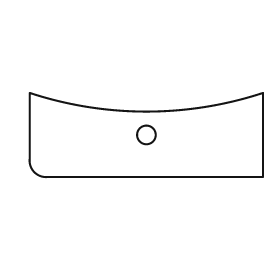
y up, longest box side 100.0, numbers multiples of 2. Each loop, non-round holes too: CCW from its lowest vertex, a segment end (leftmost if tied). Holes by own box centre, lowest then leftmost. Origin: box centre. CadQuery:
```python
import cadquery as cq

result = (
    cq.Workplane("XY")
    .moveTo(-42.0, -18.0)
    .lineTo(50.0, -18.0)
    .lineTo(50.0, 18.0)
    .threePointArc((0.0, 10.0), (-50.0, 18.0))
    .lineTo(-50.0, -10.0)
    .threePointArc((-48.0, -16.0), (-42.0, -18.0))
    .close()
    .moveTo(0.0, 0.0)
    .circle(4.0)
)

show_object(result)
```